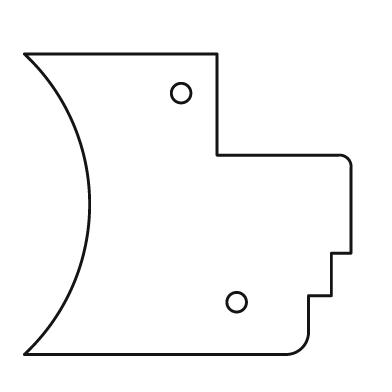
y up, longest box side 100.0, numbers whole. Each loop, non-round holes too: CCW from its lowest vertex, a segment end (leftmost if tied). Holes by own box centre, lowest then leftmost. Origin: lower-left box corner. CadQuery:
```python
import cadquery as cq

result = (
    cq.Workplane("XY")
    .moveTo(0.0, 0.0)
    .lineTo(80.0, 0.0)
    .threePointArc((85.0, 2.0), (87.0, 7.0))
    .lineTo(87.0, 18.0)
    .lineTo(94.0, 18.0)
    .lineTo(94.0, 31.0)
    .lineTo(100.0, 31.0)
    .lineTo(100.0, 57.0)
    .threePointArc((99.0, 60.0), (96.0, 61.0))
    .lineTo(59.0, 61.0)
    .lineTo(59.0, 92.0)
    .lineTo(0.0, 92.0)
    .threePointArc((20.0, 46.0), (0.0, 0.0))
    .close()
    .moveTo(65.0, 16.0)
    .circle(3.0)
    .moveTo(48.0, 80.0)
    .circle(3.0)
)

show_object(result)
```